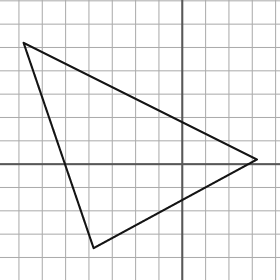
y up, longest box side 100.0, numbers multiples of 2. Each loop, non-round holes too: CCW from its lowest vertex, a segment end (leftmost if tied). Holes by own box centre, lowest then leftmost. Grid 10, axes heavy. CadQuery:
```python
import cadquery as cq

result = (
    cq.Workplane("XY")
    .moveTo(-38.0, -36.0)
    .lineTo(32.0, 2.0)
    .lineTo(-68.0, 52.0)
    .close()
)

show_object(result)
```